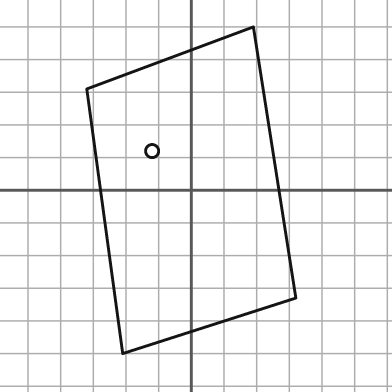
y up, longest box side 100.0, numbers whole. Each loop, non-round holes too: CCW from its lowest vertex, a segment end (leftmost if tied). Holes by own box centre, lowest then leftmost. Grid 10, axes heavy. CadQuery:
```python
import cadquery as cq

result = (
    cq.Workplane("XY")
    .moveTo(-21.0, -50.0)
    .lineTo(32.0, -33.0)
    .lineTo(19.0, 50.0)
    .lineTo(-32.0, 31.0)
    .close()
    .moveTo(-12.0, 12.0)
    .circle(2.0)
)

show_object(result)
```